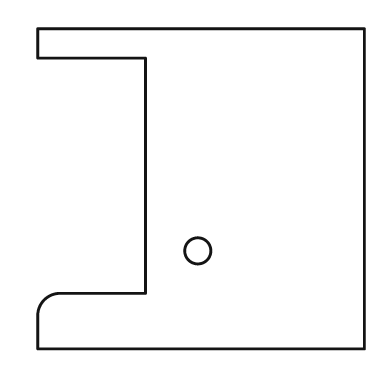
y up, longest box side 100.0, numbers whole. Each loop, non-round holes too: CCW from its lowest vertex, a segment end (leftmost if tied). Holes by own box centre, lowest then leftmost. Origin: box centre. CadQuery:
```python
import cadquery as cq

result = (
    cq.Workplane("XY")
    .moveTo(-50.0, -49.0)
    .lineTo(50.0, -49.0)
    .lineTo(50.0, 49.0)
    .lineTo(-50.0, 49.0)
    .lineTo(-50.0, 40.0)
    .lineTo(-17.0, 40.0)
    .lineTo(-17.0, -32.0)
    .lineTo(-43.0, -32.0)
    .threePointArc((-48.0, -34.0), (-50.0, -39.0))
    .close()
    .moveTo(-1.0, -19.0)
    .circle(4.0)
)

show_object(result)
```